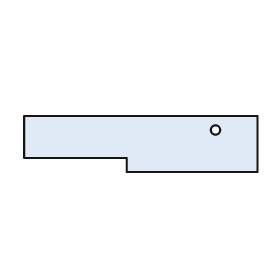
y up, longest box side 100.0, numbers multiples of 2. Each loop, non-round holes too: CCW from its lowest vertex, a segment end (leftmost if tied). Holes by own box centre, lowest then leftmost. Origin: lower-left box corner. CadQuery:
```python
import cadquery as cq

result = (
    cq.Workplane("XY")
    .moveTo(44.0, 0.0)
    .lineTo(100.0, 0.0)
    .lineTo(100.0, 24.0)
    .lineTo(0.0, 24.0)
    .lineTo(0.0, 6.0)
    .lineTo(44.0, 6.0)
    .close()
    .moveTo(82.0, 18.0)
    .circle(2.0)
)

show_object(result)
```